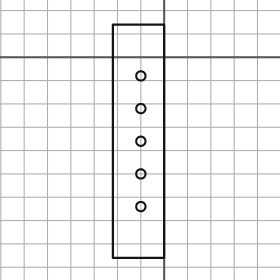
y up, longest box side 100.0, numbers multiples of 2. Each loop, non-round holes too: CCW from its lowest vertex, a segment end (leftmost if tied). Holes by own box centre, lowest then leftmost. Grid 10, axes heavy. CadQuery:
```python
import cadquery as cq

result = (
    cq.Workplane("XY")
    .moveTo(-22.0, -86.0)
    .lineTo(0.0, -86.0)
    .lineTo(0.0, 14.0)
    .lineTo(-22.0, 14.0)
    .close()
    .moveTo(-10.0, -64.0)
    .circle(2.0)
    .moveTo(-10.0, -50.0)
    .circle(2.0)
    .moveTo(-10.0, -36.0)
    .circle(2.0)
    .moveTo(-10.0, -22.0)
    .circle(2.0)
    .moveTo(-10.0, -8.0)
    .circle(2.0)
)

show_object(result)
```